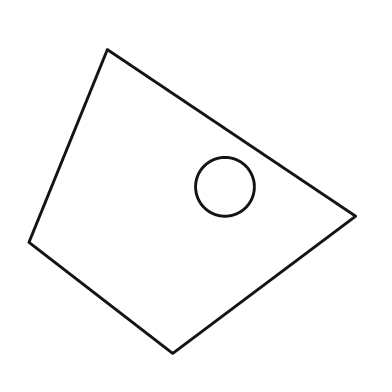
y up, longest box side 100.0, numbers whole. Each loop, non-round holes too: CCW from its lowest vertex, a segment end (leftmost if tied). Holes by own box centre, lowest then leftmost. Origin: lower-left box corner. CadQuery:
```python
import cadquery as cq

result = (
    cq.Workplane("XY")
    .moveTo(44.0, 0.0)
    .lineTo(100.0, 42.0)
    .lineTo(24.0, 93.0)
    .lineTo(0.0, 34.0)
    .close()
    .moveTo(60.0, 51.0)
    .circle(9.0)
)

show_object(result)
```